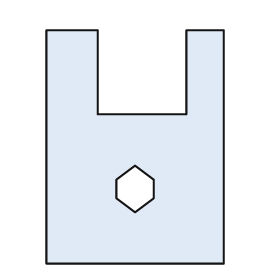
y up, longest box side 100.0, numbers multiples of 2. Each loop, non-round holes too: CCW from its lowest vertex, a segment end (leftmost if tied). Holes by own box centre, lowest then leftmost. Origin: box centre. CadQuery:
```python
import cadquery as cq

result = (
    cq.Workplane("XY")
    .moveTo(-38.0, -50.0)
    .lineTo(38.0, -50.0)
    .lineTo(38.0, 50.0)
    .lineTo(22.0, 50.0)
    .lineTo(22.0, 14.0)
    .lineTo(-16.0, 14.0)
    .lineTo(-16.0, 50.0)
    .lineTo(-38.0, 50.0)
    .close()
    .moveTo(0.0, -28.0)
    .lineTo(8.0, -22.0)
    .lineTo(8.0, -14.0)
    .lineTo(0.0, -8.0)
    .lineTo(-8.0, -14.0)
    .lineTo(-8.0, -22.0)
    .close()
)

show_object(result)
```